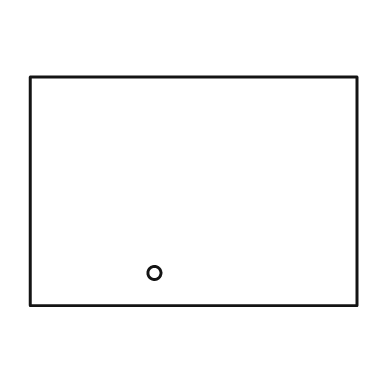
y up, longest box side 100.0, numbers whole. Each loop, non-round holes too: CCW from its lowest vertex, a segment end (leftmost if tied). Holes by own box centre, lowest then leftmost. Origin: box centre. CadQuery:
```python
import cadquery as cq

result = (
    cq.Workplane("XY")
    .moveTo(-50.0, -35.0)
    .lineTo(50.0, -35.0)
    .lineTo(50.0, 35.0)
    .lineTo(-50.0, 35.0)
    .close()
    .moveTo(-12.0, -25.0)
    .circle(2.0)
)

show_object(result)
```